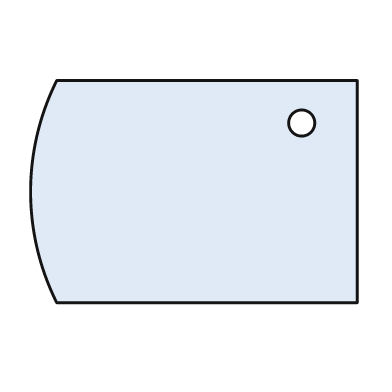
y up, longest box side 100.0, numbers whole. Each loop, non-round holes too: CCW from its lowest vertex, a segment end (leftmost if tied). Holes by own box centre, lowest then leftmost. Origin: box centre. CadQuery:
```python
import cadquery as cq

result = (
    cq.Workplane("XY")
    .moveTo(-42.0, -34.0)
    .lineTo(50.0, -34.0)
    .lineTo(50.0, 34.0)
    .lineTo(-42.0, 34.0)
    .threePointArc((-50.0, 0.0), (-42.0, -34.0))
    .close()
    .moveTo(33.0, 21.0)
    .circle(4.0)
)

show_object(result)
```